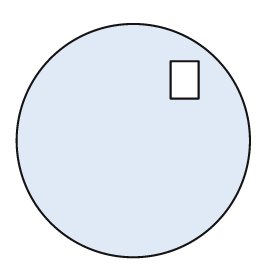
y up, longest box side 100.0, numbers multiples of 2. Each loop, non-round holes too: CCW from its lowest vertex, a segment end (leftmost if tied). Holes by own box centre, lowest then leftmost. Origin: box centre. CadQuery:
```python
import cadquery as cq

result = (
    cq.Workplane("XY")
    .moveTo(0.0, 0.0)
    .circle(50.0)
    .moveTo(16.0, 18.0)
    .lineTo(28.0, 18.0)
    .lineTo(28.0, 34.0)
    .lineTo(16.0, 34.0)
    .close()
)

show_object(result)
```